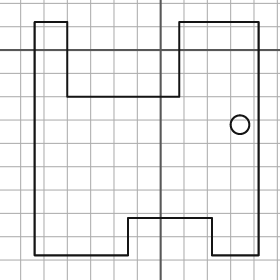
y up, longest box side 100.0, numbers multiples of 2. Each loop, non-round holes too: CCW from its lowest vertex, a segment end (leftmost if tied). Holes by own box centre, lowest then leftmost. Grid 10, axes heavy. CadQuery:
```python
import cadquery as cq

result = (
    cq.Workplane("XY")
    .moveTo(-54.0, -88.0)
    .lineTo(-14.0, -88.0)
    .lineTo(-14.0, -72.0)
    .lineTo(22.0, -72.0)
    .lineTo(22.0, -88.0)
    .lineTo(42.0, -88.0)
    .lineTo(42.0, 12.0)
    .lineTo(8.0, 12.0)
    .lineTo(8.0, -20.0)
    .lineTo(-40.0, -20.0)
    .lineTo(-40.0, 12.0)
    .lineTo(-54.0, 12.0)
    .close()
    .moveTo(34.0, -32.0)
    .circle(4.0)
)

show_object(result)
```